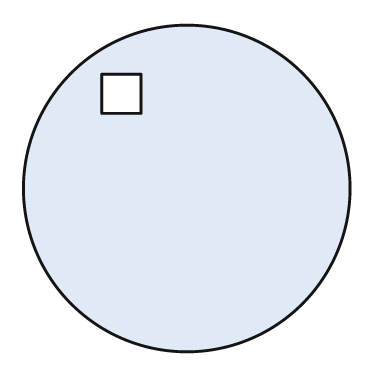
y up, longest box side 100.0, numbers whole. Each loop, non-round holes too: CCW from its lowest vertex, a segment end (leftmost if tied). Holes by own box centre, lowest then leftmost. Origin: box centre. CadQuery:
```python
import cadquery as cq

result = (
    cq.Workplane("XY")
    .moveTo(0.0, 0.0)
    .circle(50.0)
    .moveTo(-26.0, 23.0)
    .lineTo(-14.0, 23.0)
    .lineTo(-14.0, 35.0)
    .lineTo(-26.0, 35.0)
    .close()
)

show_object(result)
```